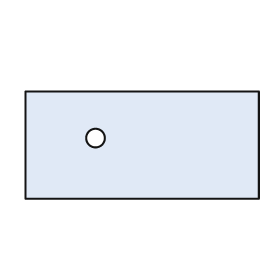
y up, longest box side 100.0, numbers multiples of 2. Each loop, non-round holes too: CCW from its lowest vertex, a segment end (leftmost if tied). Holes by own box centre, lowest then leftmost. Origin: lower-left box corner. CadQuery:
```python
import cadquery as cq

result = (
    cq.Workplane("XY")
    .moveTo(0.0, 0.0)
    .lineTo(100.0, 0.0)
    .lineTo(100.0, 46.0)
    .lineTo(0.0, 46.0)
    .close()
    .moveTo(30.0, 26.0)
    .circle(4.0)
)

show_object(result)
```